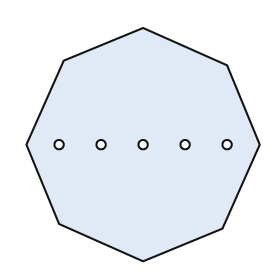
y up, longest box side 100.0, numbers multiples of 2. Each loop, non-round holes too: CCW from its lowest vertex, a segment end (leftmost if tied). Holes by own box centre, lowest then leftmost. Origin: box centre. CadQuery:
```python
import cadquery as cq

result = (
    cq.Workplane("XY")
    .moveTo(0.0, -50.0)
    .lineTo(34.0, -36.0)
    .lineTo(50.0, 0.0)
    .lineTo(36.0, 34.0)
    .lineTo(0.0, 50.0)
    .lineTo(-34.0, 36.0)
    .lineTo(-50.0, 0.0)
    .lineTo(-36.0, -34.0)
    .close()
    .moveTo(-36.0, 0.0)
    .circle(2.0)
    .moveTo(-18.0, 0.0)
    .circle(2.0)
    .moveTo(0.0, 0.0)
    .circle(2.0)
    .moveTo(18.0, 0.0)
    .circle(2.0)
    .moveTo(36.0, 0.0)
    .circle(2.0)
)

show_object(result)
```